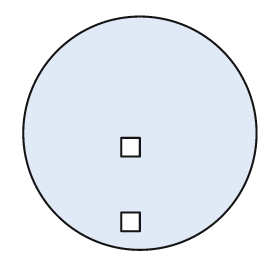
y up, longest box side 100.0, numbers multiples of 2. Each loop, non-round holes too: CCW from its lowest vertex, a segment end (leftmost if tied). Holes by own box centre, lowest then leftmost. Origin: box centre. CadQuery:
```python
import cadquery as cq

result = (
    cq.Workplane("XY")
    .moveTo(0.0, 0.0)
    .circle(50.0)
    .moveTo(-8.0, -42.0)
    .lineTo(0.0, -42.0)
    .lineTo(0.0, -34.0)
    .lineTo(-8.0, -34.0)
    .close()
    .moveTo(-8.0, -10.0)
    .lineTo(0.0, -10.0)
    .lineTo(0.0, -2.0)
    .lineTo(-8.0, -2.0)
    .close()
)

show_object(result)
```